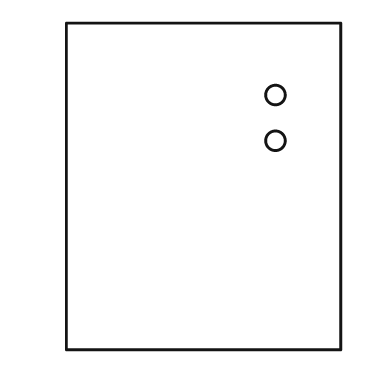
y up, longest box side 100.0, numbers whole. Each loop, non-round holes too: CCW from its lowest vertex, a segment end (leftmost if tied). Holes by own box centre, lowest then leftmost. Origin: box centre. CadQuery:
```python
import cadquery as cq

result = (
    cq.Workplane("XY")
    .moveTo(-42.0, -50.0)
    .lineTo(42.0, -50.0)
    .lineTo(42.0, 50.0)
    .lineTo(-42.0, 50.0)
    .close()
    .moveTo(22.0, 14.0)
    .circle(3.0)
    .moveTo(22.0, 28.0)
    .circle(3.0)
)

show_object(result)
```